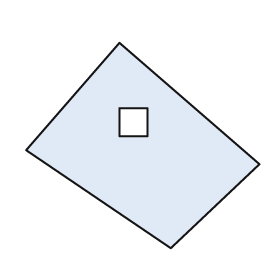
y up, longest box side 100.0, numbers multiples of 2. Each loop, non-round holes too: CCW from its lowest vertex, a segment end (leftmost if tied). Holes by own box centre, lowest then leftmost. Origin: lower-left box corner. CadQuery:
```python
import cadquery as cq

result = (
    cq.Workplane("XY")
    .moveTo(62.0, 0.0)
    .lineTo(100.0, 36.0)
    .lineTo(40.0, 88.0)
    .lineTo(0.0, 42.0)
    .close()
    .moveTo(40.0, 48.0)
    .lineTo(52.0, 48.0)
    .lineTo(52.0, 60.0)
    .lineTo(40.0, 60.0)
    .close()
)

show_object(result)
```